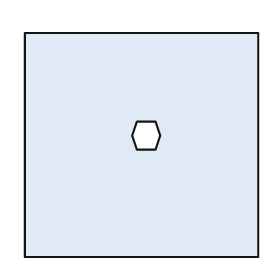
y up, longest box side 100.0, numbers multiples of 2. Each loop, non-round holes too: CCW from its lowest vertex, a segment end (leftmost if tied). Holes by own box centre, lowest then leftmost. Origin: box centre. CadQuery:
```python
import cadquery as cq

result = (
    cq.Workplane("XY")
    .moveTo(-50.0, -48.0)
    .lineTo(50.0, -48.0)
    .lineTo(50.0, 48.0)
    .lineTo(-50.0, 48.0)
    .close()
    .moveTo(-2.0, -2.0)
    .lineTo(6.0, -2.0)
    .lineTo(8.0, 4.0)
    .lineTo(6.0, 10.0)
    .lineTo(-2.0, 10.0)
    .lineTo(-4.0, 4.0)
    .close()
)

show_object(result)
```